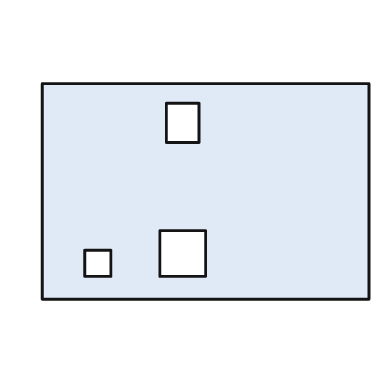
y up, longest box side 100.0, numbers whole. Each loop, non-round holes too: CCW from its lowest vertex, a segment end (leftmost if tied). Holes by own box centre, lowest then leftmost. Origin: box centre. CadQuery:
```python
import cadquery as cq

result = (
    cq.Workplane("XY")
    .moveTo(-50.0, -33.0)
    .lineTo(50.0, -33.0)
    .lineTo(50.0, 33.0)
    .lineTo(-50.0, 33.0)
    .close()
    .moveTo(-37.0, -26.0)
    .lineTo(-29.0, -26.0)
    .lineTo(-29.0, -18.0)
    .lineTo(-37.0, -18.0)
    .close()
    .moveTo(-14.0, -26.0)
    .lineTo(0.0, -26.0)
    .lineTo(0.0, -12.0)
    .lineTo(-14.0, -12.0)
    .close()
    .moveTo(-12.0, 15.0)
    .lineTo(-2.0, 15.0)
    .lineTo(-2.0, 27.0)
    .lineTo(-12.0, 27.0)
    .close()
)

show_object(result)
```